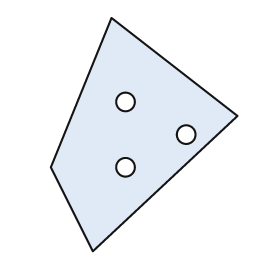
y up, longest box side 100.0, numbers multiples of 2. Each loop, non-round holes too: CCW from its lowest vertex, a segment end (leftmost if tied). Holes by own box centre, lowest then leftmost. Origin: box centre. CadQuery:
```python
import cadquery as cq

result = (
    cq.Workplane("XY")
    .moveTo(-22.0, -50.0)
    .lineTo(40.0, 8.0)
    .lineTo(-14.0, 50.0)
    .lineTo(-40.0, -14.0)
    .close()
    .moveTo(-8.0, -14.0)
    .circle(4.0)
    .moveTo(18.0, 0.0)
    .circle(4.0)
    .moveTo(-8.0, 14.0)
    .circle(4.0)
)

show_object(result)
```